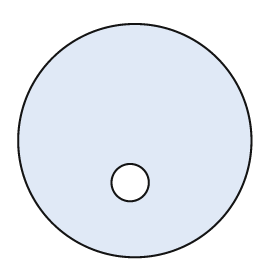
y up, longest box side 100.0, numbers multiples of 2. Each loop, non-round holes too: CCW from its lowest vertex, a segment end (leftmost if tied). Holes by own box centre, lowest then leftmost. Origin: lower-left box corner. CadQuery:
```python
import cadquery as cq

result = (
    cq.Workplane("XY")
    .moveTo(50.0, 50.0)
    .circle(50.0)
    .moveTo(48.0, 32.0)
    .circle(8.0)
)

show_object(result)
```